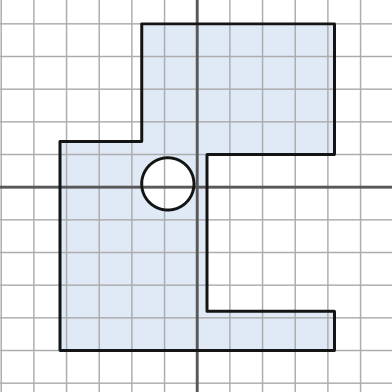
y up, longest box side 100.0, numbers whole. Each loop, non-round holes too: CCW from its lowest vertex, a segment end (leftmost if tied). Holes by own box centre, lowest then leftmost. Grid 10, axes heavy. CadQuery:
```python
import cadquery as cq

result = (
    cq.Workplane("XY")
    .moveTo(-42.0, -50.0)
    .lineTo(42.0, -50.0)
    .lineTo(42.0, -38.0)
    .lineTo(3.0, -38.0)
    .lineTo(3.0, 10.0)
    .lineTo(42.0, 10.0)
    .lineTo(42.0, 50.0)
    .lineTo(-17.0, 50.0)
    .lineTo(-17.0, 14.0)
    .lineTo(-42.0, 14.0)
    .close()
    .moveTo(-9.0, 1.0)
    .circle(8.0)
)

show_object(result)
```